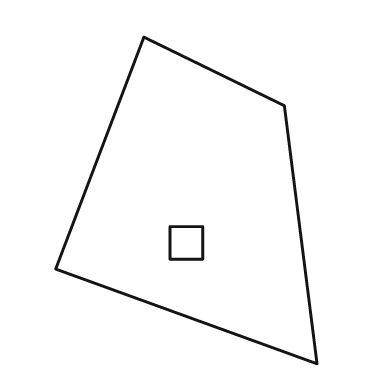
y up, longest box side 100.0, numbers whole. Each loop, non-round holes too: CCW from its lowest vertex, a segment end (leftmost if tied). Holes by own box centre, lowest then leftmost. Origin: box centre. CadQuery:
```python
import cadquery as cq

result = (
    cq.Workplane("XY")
    .moveTo(40.0, -50.0)
    .lineTo(30.0, 29.0)
    .lineTo(-13.0, 50.0)
    .lineTo(-40.0, -21.0)
    .close()
    .moveTo(-5.0, -18.0)
    .lineTo(5.0, -18.0)
    .lineTo(5.0, -8.0)
    .lineTo(-5.0, -8.0)
    .close()
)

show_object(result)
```